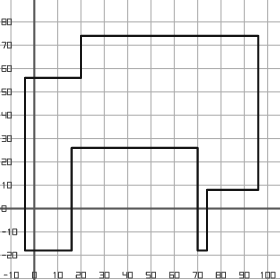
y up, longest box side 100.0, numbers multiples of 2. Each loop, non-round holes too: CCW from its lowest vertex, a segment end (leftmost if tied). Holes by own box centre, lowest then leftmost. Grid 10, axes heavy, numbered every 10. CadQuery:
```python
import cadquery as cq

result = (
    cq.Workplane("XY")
    .moveTo(-4.0, -18.0)
    .lineTo(16.0, -18.0)
    .lineTo(16.0, 26.0)
    .lineTo(70.0, 26.0)
    .lineTo(70.0, -18.0)
    .lineTo(74.0, -18.0)
    .lineTo(74.0, 8.0)
    .lineTo(96.0, 8.0)
    .lineTo(96.0, 74.0)
    .lineTo(20.0, 74.0)
    .lineTo(20.0, 56.0)
    .lineTo(-4.0, 56.0)
    .close()
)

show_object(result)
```